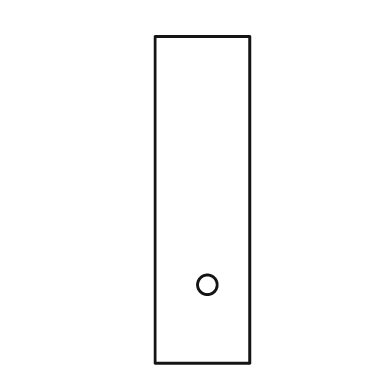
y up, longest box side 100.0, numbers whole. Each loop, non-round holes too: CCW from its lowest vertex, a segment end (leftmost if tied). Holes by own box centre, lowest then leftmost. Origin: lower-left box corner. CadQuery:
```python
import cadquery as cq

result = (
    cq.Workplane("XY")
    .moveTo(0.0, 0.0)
    .lineTo(29.0, 0.0)
    .lineTo(29.0, 100.0)
    .lineTo(0.0, 100.0)
    .close()
    .moveTo(16.0, 24.0)
    .circle(3.0)
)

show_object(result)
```